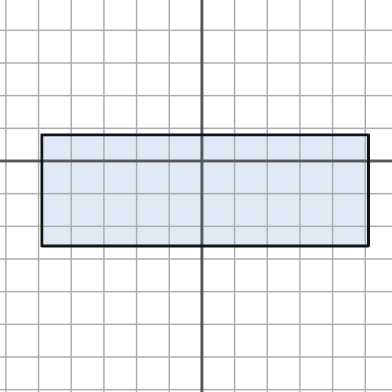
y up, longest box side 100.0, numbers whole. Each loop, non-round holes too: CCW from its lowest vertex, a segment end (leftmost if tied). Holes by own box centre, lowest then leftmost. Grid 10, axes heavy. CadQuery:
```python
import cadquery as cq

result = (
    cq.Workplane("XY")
    .moveTo(-49.0, -26.0)
    .lineTo(51.0, -26.0)
    .lineTo(51.0, 8.0)
    .lineTo(-49.0, 8.0)
    .close()
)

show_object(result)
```